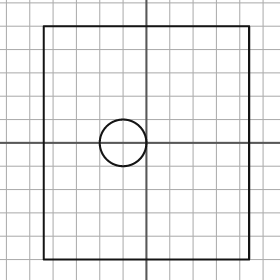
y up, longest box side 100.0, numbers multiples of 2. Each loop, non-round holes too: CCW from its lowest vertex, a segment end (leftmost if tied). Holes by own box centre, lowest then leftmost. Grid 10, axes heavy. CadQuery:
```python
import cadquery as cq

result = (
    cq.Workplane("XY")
    .moveTo(-44.0, -50.0)
    .lineTo(44.0, -50.0)
    .lineTo(44.0, 50.0)
    .lineTo(-44.0, 50.0)
    .close()
    .moveTo(-10.0, 0.0)
    .circle(10.0)
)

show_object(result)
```